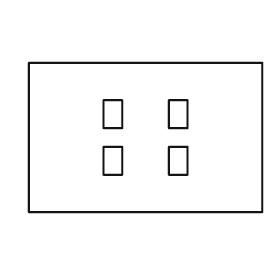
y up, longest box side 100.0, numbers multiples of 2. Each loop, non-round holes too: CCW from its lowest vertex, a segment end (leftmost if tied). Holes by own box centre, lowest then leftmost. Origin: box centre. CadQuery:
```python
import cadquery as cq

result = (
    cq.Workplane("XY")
    .moveTo(-50.0, -32.0)
    .lineTo(50.0, -32.0)
    .lineTo(50.0, 32.0)
    .lineTo(-50.0, 32.0)
    .close()
    .moveTo(-18.0, -16.0)
    .lineTo(-10.0, -16.0)
    .lineTo(-10.0, -4.0)
    .lineTo(-18.0, -4.0)
    .close()
    .moveTo(10.0, -16.0)
    .lineTo(18.0, -16.0)
    .lineTo(18.0, -4.0)
    .lineTo(10.0, -4.0)
    .close()
    .moveTo(-18.0, 4.0)
    .lineTo(-10.0, 4.0)
    .lineTo(-10.0, 16.0)
    .lineTo(-18.0, 16.0)
    .close()
    .moveTo(10.0, 4.0)
    .lineTo(18.0, 4.0)
    .lineTo(18.0, 16.0)
    .lineTo(10.0, 16.0)
    .close()
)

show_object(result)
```